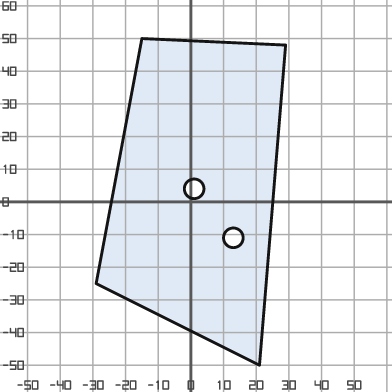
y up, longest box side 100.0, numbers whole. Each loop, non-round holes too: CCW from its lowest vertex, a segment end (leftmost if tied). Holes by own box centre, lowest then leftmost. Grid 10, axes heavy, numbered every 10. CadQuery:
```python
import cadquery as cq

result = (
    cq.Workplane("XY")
    .moveTo(21.0, -50.0)
    .lineTo(29.0, 48.0)
    .lineTo(-15.0, 50.0)
    .lineTo(-29.0, -25.0)
    .close()
    .moveTo(13.0, -11.0)
    .circle(3.0)
    .moveTo(1.0, 4.0)
    .circle(3.0)
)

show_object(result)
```